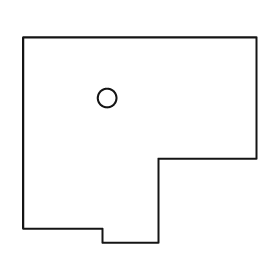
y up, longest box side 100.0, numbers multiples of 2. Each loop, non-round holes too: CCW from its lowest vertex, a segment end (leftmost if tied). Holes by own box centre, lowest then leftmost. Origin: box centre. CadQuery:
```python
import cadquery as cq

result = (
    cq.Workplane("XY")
    .moveTo(-16.0, -44.0)
    .lineTo(8.0, -44.0)
    .lineTo(8.0, -8.0)
    .lineTo(50.0, -8.0)
    .lineTo(50.0, 44.0)
    .lineTo(-50.0, 44.0)
    .lineTo(-50.0, -38.0)
    .lineTo(-16.0, -38.0)
    .close()
    .moveTo(-14.0, 18.0)
    .circle(4.0)
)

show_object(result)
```